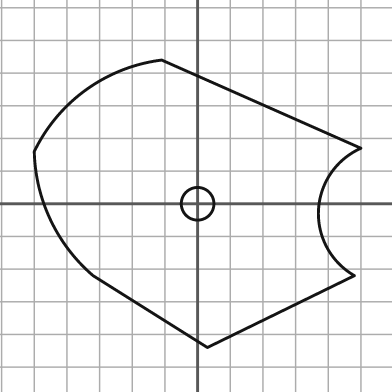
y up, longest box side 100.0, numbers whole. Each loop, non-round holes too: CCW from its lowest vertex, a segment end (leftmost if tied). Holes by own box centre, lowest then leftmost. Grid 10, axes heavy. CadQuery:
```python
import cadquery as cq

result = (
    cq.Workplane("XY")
    .moveTo(3.0, -44.0)
    .lineTo(48.0, -22.0)
    .threePointArc((37.0, -2.0), (50.0, 17.0))
    .lineTo(-11.0, 44.0)
    .threePointArc((-34.0, 35.0), (-50.0, 16.0))
    .threePointArc((-45.0, -5.0), (-32.0, -22.0))
    .close()
    .moveTo(0.0, 0.0)
    .circle(5.0)
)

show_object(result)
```